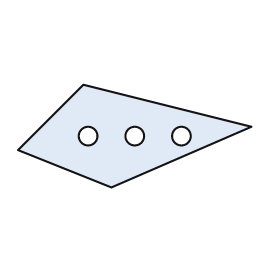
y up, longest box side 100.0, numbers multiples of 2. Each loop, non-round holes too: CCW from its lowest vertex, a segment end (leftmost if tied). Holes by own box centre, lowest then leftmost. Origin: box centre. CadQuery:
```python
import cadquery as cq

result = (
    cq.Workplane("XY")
    .moveTo(-10.0, -22.0)
    .lineTo(50.0, 4.0)
    .lineTo(-22.0, 22.0)
    .lineTo(-50.0, -6.0)
    .close()
    .moveTo(-20.0, 0.0)
    .circle(4.0)
    .moveTo(0.0, 0.0)
    .circle(4.0)
    .moveTo(20.0, 0.0)
    .circle(4.0)
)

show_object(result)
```